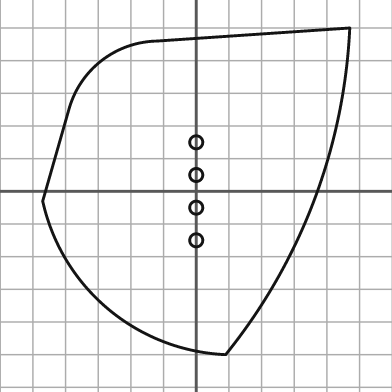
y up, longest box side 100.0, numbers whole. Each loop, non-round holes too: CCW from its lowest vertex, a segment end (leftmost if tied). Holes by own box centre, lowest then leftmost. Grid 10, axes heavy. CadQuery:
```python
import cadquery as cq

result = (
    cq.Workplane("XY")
    .moveTo(9.0, -50.0)
    .threePointArc((36.0, -3.0), (47.0, 50.0))
    .lineTo(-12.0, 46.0)
    .threePointArc((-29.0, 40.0), (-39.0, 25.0))
    .lineTo(-47.0, -3.0)
    .threePointArc((-27.0, -36.0), (9.0, -50.0))
    .close()
    .moveTo(0.0, -15.0)
    .circle(2.0)
    .moveTo(0.0, -5.0)
    .circle(2.0)
    .moveTo(0.0, 5.0)
    .circle(2.0)
    .moveTo(0.0, 15.0)
    .circle(2.0)
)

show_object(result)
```